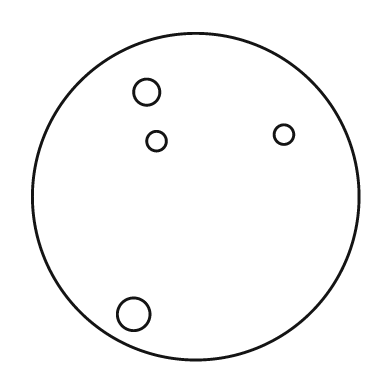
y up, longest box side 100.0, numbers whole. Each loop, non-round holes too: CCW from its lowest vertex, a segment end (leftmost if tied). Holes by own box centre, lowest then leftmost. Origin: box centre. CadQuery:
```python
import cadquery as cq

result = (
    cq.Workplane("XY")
    .moveTo(0.0, 0.0)
    .circle(50.0)
    .moveTo(-19.0, -36.0)
    .circle(5.0)
    .moveTo(-12.0, 17.0)
    .circle(3.0)
    .moveTo(27.0, 19.0)
    .circle(3.0)
    .moveTo(-15.0, 32.0)
    .circle(4.0)
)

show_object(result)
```